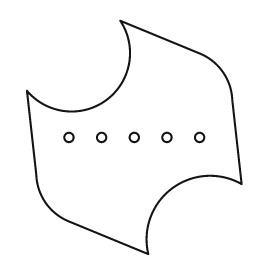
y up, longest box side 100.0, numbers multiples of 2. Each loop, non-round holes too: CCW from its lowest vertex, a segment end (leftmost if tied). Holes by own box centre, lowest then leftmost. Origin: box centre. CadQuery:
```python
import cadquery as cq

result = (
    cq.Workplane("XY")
    .moveTo(6.0, -50.0)
    .threePointArc((16.0, -22.0), (46.0, -20.0))
    .lineTo(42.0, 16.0)
    .threePointArc((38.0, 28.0), (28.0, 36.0))
    .lineTo(-6.0, 50.0)
    .threePointArc((-12.0, 16.0), (-46.0, 20.0))
    .lineTo(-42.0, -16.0)
    .threePointArc((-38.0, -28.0), (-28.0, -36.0))
    .close()
    .moveTo(-28.0, 0.0)
    .circle(2.0)
    .moveTo(-14.0, 0.0)
    .circle(2.0)
    .moveTo(0.0, 0.0)
    .circle(2.0)
    .moveTo(14.0, 0.0)
    .circle(2.0)
    .moveTo(28.0, 0.0)
    .circle(2.0)
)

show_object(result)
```